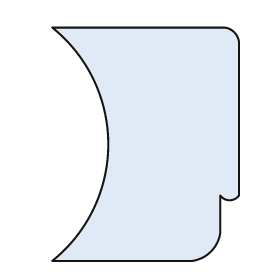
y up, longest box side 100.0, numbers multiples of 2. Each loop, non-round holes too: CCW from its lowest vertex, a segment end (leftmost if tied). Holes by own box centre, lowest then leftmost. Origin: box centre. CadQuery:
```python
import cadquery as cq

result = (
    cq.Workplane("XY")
    .moveTo(-40.0, -50.0)
    .lineTo(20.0, -50.0)
    .threePointArc((28.0, -46.0), (32.0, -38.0))
    .lineTo(32.0, -22.0)
    .threePointArc((36.0, -24.0), (40.0, -22.0))
    .lineTo(40.0, 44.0)
    .threePointArc((38.0, 48.0), (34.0, 50.0))
    .lineTo(-40.0, 50.0)
    .threePointArc((-16.0, 0.0), (-40.0, -50.0))
    .close()
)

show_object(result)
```